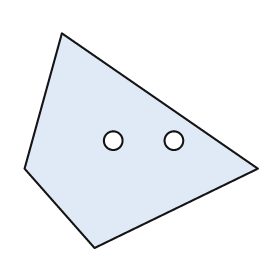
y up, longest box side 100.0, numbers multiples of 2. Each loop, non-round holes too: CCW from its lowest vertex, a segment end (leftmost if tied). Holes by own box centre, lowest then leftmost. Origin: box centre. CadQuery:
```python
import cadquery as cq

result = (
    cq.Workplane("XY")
    .moveTo(-20.0, -46.0)
    .lineTo(50.0, -12.0)
    .lineTo(-34.0, 46.0)
    .lineTo(-50.0, -12.0)
    .close()
    .moveTo(-12.0, 0.0)
    .circle(4.0)
    .moveTo(14.0, 0.0)
    .circle(4.0)
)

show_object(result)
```